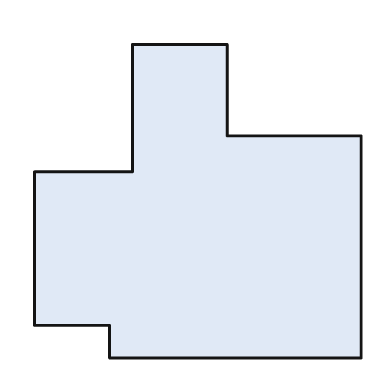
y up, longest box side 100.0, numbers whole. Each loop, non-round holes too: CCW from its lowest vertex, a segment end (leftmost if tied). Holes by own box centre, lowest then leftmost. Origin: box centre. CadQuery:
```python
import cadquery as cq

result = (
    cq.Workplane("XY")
    .moveTo(-27.0, -48.0)
    .lineTo(50.0, -48.0)
    .lineTo(50.0, 20.0)
    .lineTo(9.0, 20.0)
    .lineTo(9.0, 48.0)
    .lineTo(-20.0, 48.0)
    .lineTo(-20.0, 9.0)
    .lineTo(-50.0, 9.0)
    .lineTo(-50.0, -38.0)
    .lineTo(-27.0, -38.0)
    .close()
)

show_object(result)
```